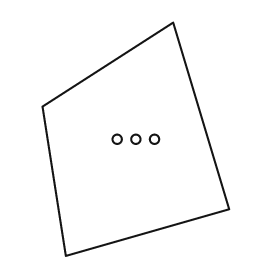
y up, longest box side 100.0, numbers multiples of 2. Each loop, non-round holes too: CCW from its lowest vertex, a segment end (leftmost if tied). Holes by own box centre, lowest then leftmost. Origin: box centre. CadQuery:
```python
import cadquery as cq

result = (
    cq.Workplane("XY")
    .moveTo(-30.0, -50.0)
    .lineTo(40.0, -30.0)
    .lineTo(16.0, 50.0)
    .lineTo(-40.0, 14.0)
    .close()
    .moveTo(-8.0, 0.0)
    .circle(2.0)
    .moveTo(0.0, 0.0)
    .circle(2.0)
    .moveTo(8.0, 0.0)
    .circle(2.0)
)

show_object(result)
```